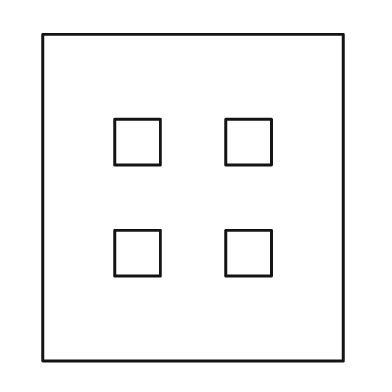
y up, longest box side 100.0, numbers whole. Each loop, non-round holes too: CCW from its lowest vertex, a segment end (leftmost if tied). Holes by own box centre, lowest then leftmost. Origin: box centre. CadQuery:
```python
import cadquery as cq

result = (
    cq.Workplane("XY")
    .moveTo(-46.0, -50.0)
    .lineTo(46.0, -50.0)
    .lineTo(46.0, 50.0)
    .lineTo(-46.0, 50.0)
    .close()
    .moveTo(-24.0, -24.0)
    .lineTo(-10.0, -24.0)
    .lineTo(-10.0, -10.0)
    .lineTo(-24.0, -10.0)
    .close()
    .moveTo(10.0, -24.0)
    .lineTo(24.0, -24.0)
    .lineTo(24.0, -10.0)
    .lineTo(10.0, -10.0)
    .close()
    .moveTo(-24.0, 10.0)
    .lineTo(-10.0, 10.0)
    .lineTo(-10.0, 24.0)
    .lineTo(-24.0, 24.0)
    .close()
    .moveTo(10.0, 10.0)
    .lineTo(24.0, 10.0)
    .lineTo(24.0, 24.0)
    .lineTo(10.0, 24.0)
    .close()
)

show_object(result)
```